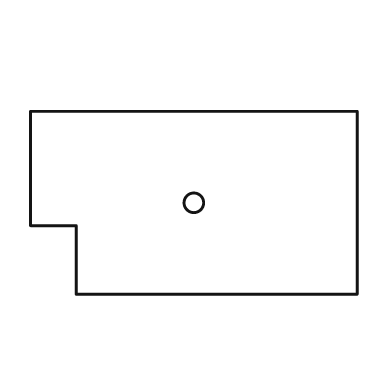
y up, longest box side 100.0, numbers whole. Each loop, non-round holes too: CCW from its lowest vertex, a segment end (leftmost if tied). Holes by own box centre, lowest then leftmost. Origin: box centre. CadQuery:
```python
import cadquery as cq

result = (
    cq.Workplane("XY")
    .moveTo(-36.0, -28.0)
    .lineTo(50.0, -28.0)
    .lineTo(50.0, 28.0)
    .lineTo(-50.0, 28.0)
    .lineTo(-50.0, -7.0)
    .lineTo(-36.0, -7.0)
    .close()
    .moveTo(0.0, 0.0)
    .circle(3.0)
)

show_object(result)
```